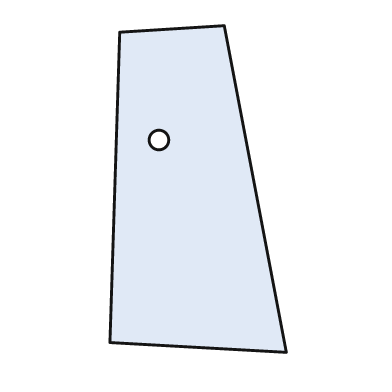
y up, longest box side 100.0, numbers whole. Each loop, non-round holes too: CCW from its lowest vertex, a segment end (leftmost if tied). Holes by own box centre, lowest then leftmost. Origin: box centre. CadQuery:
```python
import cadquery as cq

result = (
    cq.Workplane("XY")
    .moveTo(27.0, -50.0)
    .lineTo(8.0, 50.0)
    .lineTo(-24.0, 48.0)
    .lineTo(-27.0, -47.0)
    .close()
    .moveTo(-12.0, 15.0)
    .circle(3.0)
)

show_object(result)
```